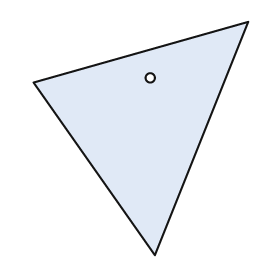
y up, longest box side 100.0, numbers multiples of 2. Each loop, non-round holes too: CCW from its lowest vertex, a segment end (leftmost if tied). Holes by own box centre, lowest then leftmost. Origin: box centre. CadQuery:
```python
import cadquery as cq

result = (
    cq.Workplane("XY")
    .moveTo(6.0, -50.0)
    .lineTo(46.0, 50.0)
    .lineTo(-46.0, 24.0)
    .close()
    .moveTo(4.0, 26.0)
    .circle(2.0)
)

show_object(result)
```